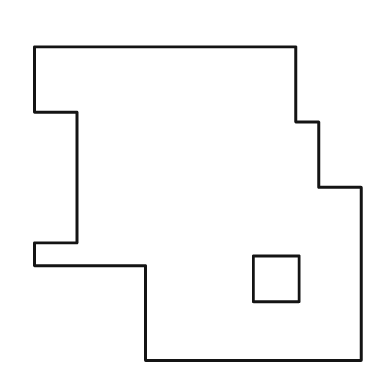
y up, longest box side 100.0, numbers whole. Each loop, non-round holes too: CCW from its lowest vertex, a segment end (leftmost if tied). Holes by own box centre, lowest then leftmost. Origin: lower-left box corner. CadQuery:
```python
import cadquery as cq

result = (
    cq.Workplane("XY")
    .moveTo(34.0, 0.0)
    .lineTo(100.0, 0.0)
    .lineTo(100.0, 53.0)
    .lineTo(87.0, 53.0)
    .lineTo(87.0, 73.0)
    .lineTo(80.0, 73.0)
    .lineTo(80.0, 96.0)
    .lineTo(0.0, 96.0)
    .lineTo(0.0, 76.0)
    .lineTo(13.0, 76.0)
    .lineTo(13.0, 36.0)
    .lineTo(0.0, 36.0)
    .lineTo(0.0, 29.0)
    .lineTo(34.0, 29.0)
    .close()
    .moveTo(67.0, 18.0)
    .lineTo(81.0, 18.0)
    .lineTo(81.0, 32.0)
    .lineTo(67.0, 32.0)
    .close()
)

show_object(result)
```